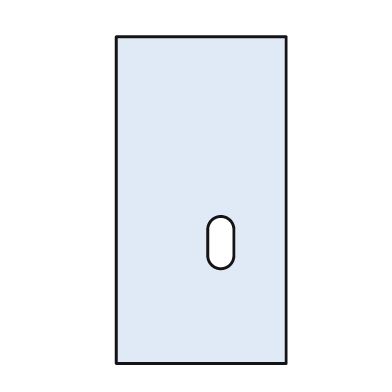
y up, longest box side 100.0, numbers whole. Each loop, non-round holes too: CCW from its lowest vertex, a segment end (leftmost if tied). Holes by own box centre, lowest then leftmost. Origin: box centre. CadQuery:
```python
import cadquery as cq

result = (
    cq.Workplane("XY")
    .moveTo(-26.0, -50.0)
    .lineTo(26.0, -50.0)
    .lineTo(26.0, 50.0)
    .lineTo(-26.0, 50.0)
    .close()
    .moveTo(2.0, -17.0)
    .threePointArc((6.0, -21.0), (10.0, -17.0))
    .lineTo(10.0, -9.0)
    .threePointArc((6.0, -5.0), (2.0, -9.0))
    .close()
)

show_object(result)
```